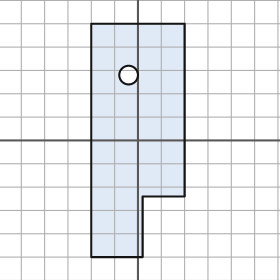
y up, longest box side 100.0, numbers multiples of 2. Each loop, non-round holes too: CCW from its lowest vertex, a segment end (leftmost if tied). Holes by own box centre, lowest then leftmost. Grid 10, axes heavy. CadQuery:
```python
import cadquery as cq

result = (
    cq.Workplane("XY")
    .moveTo(-20.0, -50.0)
    .lineTo(2.0, -50.0)
    .lineTo(2.0, -24.0)
    .lineTo(20.0, -24.0)
    .lineTo(20.0, 50.0)
    .lineTo(-20.0, 50.0)
    .close()
    .moveTo(-4.0, 28.0)
    .circle(4.0)
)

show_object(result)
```